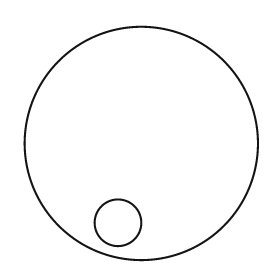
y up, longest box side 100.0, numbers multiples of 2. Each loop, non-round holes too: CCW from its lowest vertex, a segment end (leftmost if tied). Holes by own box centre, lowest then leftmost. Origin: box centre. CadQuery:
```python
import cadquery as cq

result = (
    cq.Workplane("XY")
    .moveTo(0.0, 0.0)
    .circle(50.0)
    .moveTo(-10.0, -34.0)
    .circle(10.0)
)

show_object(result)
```